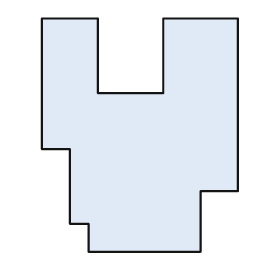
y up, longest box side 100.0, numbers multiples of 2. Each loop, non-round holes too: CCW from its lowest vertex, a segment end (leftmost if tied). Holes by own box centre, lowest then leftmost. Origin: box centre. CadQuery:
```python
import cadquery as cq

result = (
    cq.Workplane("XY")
    .moveTo(-22.0, -50.0)
    .lineTo(26.0, -50.0)
    .lineTo(26.0, -24.0)
    .lineTo(42.0, -24.0)
    .lineTo(42.0, 50.0)
    .lineTo(10.0, 50.0)
    .lineTo(10.0, 18.0)
    .lineTo(-18.0, 18.0)
    .lineTo(-18.0, 50.0)
    .lineTo(-42.0, 50.0)
    .lineTo(-42.0, -6.0)
    .lineTo(-30.0, -6.0)
    .lineTo(-30.0, -38.0)
    .lineTo(-22.0, -38.0)
    .close()
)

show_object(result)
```